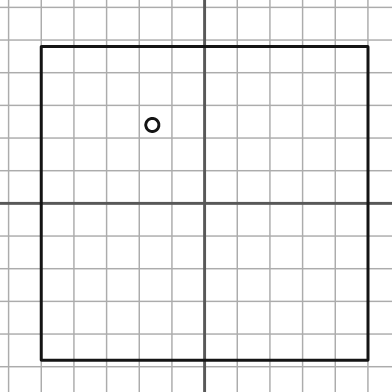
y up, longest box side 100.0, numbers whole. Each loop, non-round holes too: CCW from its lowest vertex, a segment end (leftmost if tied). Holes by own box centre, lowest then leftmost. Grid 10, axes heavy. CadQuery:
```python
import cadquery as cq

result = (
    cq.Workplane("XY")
    .moveTo(-50.0, -48.0)
    .lineTo(50.0, -48.0)
    .lineTo(50.0, 48.0)
    .lineTo(-50.0, 48.0)
    .close()
    .moveTo(-16.0, 24.0)
    .circle(2.0)
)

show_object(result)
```